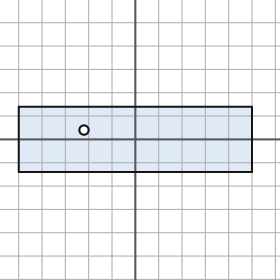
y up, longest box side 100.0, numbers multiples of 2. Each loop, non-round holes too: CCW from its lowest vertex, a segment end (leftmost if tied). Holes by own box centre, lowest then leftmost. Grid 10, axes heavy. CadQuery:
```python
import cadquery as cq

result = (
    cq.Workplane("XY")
    .moveTo(-50.0, -14.0)
    .lineTo(50.0, -14.0)
    .lineTo(50.0, 14.0)
    .lineTo(-50.0, 14.0)
    .close()
    .moveTo(-22.0, 4.0)
    .circle(2.0)
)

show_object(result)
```